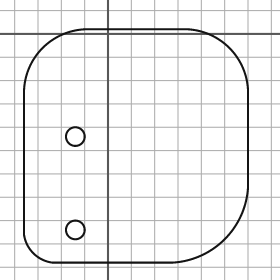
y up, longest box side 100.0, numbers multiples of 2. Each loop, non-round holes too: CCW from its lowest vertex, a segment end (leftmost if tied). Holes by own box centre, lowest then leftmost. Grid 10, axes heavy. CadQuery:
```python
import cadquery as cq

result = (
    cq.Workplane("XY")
    .moveTo(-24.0, -98.0)
    .lineTo(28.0, -98.0)
    .threePointArc((50.0, -88.0), (60.0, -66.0))
    .lineTo(60.0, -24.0)
    .threePointArc((52.0, -6.0), (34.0, 2.0))
    .lineTo(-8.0, 2.0)
    .threePointArc((-28.0, -6.0), (-36.0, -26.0))
    .lineTo(-36.0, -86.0)
    .threePointArc((-32.0, -94.0), (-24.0, -98.0))
    .close()
    .moveTo(-14.0, -84.0)
    .circle(4.0)
    .moveTo(-14.0, -44.0)
    .circle(4.0)
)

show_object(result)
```